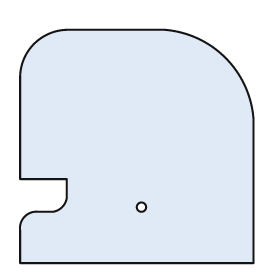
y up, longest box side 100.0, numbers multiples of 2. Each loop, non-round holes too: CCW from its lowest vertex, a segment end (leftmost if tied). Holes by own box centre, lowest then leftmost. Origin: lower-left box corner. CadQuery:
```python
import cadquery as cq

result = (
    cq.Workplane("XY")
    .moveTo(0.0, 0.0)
    .lineTo(100.0, 0.0)
    .lineTo(100.0, 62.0)
    .threePointArc((88.0, 88.0), (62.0, 100.0))
    .lineTo(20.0, 100.0)
    .threePointArc((6.0, 94.0), (0.0, 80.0))
    .lineTo(0.0, 36.0)
    .lineTo(20.0, 36.0)
    .lineTo(20.0, 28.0)
    .threePointArc((18.0, 24.0), (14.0, 22.0))
    .lineTo(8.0, 22.0)
    .threePointArc((2.0, 20.0), (0.0, 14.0))
    .close()
    .moveTo(52.0, 24.0)
    .circle(2.0)
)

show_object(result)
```